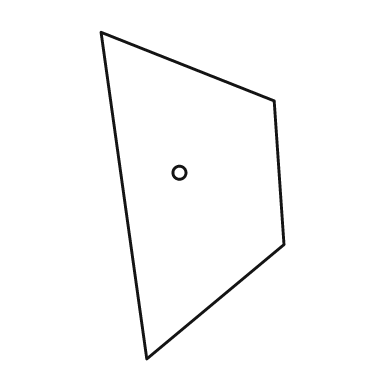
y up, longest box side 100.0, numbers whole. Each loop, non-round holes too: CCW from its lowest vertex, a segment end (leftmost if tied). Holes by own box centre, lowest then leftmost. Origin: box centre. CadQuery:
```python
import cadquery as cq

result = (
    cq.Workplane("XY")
    .moveTo(-14.0, -50.0)
    .lineTo(28.0, -15.0)
    .lineTo(25.0, 29.0)
    .lineTo(-28.0, 50.0)
    .close()
    .moveTo(-4.0, 7.0)
    .circle(2.0)
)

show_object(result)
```